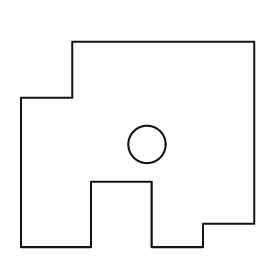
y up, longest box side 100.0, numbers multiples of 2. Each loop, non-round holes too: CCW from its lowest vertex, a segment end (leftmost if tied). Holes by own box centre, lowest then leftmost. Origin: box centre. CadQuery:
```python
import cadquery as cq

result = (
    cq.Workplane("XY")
    .moveTo(-50.0, -44.0)
    .lineTo(-20.0, -44.0)
    .lineTo(-20.0, -16.0)
    .lineTo(6.0, -16.0)
    .lineTo(6.0, -44.0)
    .lineTo(28.0, -44.0)
    .lineTo(28.0, -34.0)
    .lineTo(50.0, -34.0)
    .lineTo(50.0, 44.0)
    .lineTo(-28.0, 44.0)
    .lineTo(-28.0, 20.0)
    .lineTo(-50.0, 20.0)
    .close()
    .moveTo(4.0, 0.0)
    .circle(8.0)
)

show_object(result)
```